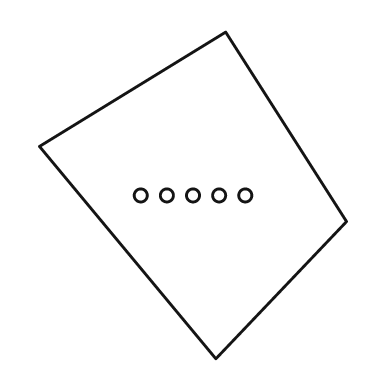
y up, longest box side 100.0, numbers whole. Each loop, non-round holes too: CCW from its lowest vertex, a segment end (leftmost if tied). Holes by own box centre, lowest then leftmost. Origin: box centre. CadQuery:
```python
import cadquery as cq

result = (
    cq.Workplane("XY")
    .moveTo(7.0, -50.0)
    .lineTo(47.0, -8.0)
    .lineTo(10.0, 50.0)
    .lineTo(-47.0, 15.0)
    .close()
    .moveTo(-16.0, 0.0)
    .circle(2.0)
    .moveTo(-8.0, 0.0)
    .circle(2.0)
    .moveTo(0.0, 0.0)
    .circle(2.0)
    .moveTo(8.0, 0.0)
    .circle(2.0)
    .moveTo(16.0, 0.0)
    .circle(2.0)
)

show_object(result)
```